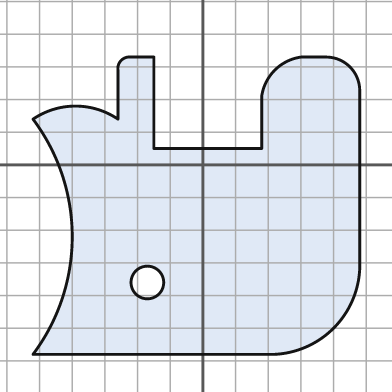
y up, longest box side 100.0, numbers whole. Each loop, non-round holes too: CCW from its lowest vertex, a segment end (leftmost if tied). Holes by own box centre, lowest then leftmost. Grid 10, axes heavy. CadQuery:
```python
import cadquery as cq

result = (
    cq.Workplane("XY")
    .moveTo(-52.0, -58.0)
    .lineTo(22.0, -58.0)
    .threePointArc((40.0, -50.0), (48.0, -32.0))
    .lineTo(48.0, 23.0)
    .threePointArc((45.0, 30.0), (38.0, 33.0))
    .lineTo(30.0, 33.0)
    .threePointArc((22.0, 29.0), (18.0, 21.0))
    .lineTo(18.0, 5.0)
    .lineTo(-15.0, 5.0)
    .lineTo(-15.0, 33.0)
    .lineTo(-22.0, 33.0)
    .threePointArc((-25.0, 32.0), (-26.0, 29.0))
    .lineTo(-26.0, 14.0)
    .threePointArc((-39.0, 18.0), (-52.0, 14.0))
    .threePointArc((-40.0, -22.0), (-52.0, -58.0))
    .close()
    .moveTo(-17.0, -36.0)
    .circle(5.0)
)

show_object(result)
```